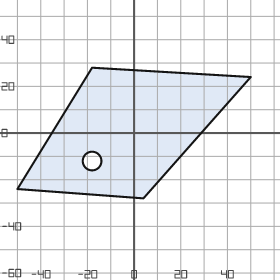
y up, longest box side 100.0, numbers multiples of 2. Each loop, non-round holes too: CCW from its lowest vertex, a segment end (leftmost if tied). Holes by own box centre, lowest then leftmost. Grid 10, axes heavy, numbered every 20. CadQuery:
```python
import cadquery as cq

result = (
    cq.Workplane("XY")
    .moveTo(4.0, -28.0)
    .lineTo(50.0, 24.0)
    .lineTo(-18.0, 28.0)
    .lineTo(-50.0, -24.0)
    .close()
    .moveTo(-18.0, -12.0)
    .circle(4.0)
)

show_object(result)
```